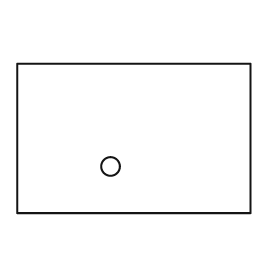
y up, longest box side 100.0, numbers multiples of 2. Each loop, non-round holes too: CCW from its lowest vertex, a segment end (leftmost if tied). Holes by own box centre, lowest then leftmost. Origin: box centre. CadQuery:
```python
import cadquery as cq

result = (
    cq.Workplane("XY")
    .moveTo(-50.0, -32.0)
    .lineTo(50.0, -32.0)
    .lineTo(50.0, 32.0)
    .lineTo(-50.0, 32.0)
    .close()
    .moveTo(-10.0, -12.0)
    .circle(4.0)
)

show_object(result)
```